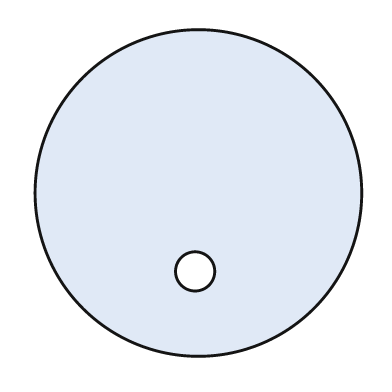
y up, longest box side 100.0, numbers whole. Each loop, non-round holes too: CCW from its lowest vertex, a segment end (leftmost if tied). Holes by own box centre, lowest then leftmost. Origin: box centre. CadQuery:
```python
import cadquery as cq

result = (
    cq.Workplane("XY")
    .moveTo(0.0, 0.0)
    .circle(50.0)
    .moveTo(-1.0, -24.0)
    .circle(6.0)
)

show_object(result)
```